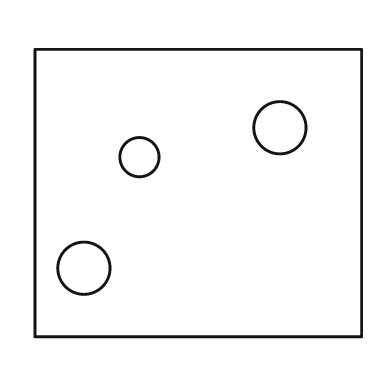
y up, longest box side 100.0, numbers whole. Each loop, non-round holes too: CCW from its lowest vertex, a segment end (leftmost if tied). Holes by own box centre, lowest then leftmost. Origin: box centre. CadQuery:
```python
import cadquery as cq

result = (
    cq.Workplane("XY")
    .moveTo(-50.0, -44.0)
    .lineTo(50.0, -44.0)
    .lineTo(50.0, 44.0)
    .lineTo(-50.0, 44.0)
    .close()
    .moveTo(-35.0, -23.0)
    .circle(8.0)
    .moveTo(-18.0, 11.0)
    .circle(6.0)
    .moveTo(25.0, 20.0)
    .circle(8.0)
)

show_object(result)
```